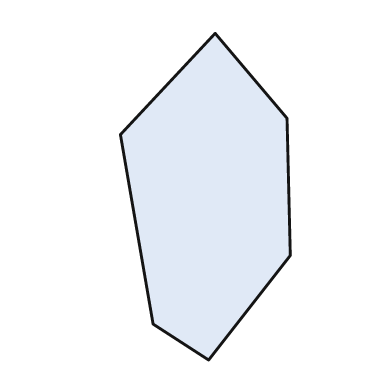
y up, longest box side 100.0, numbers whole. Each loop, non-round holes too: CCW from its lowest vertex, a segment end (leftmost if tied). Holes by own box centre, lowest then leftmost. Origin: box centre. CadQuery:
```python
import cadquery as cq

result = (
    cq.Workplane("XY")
    .moveTo(1.0, -50.0)
    .lineTo(26.0, -18.0)
    .lineTo(25.0, 24.0)
    .lineTo(3.0, 50.0)
    .lineTo(-26.0, 19.0)
    .lineTo(-16.0, -39.0)
    .close()
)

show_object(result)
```